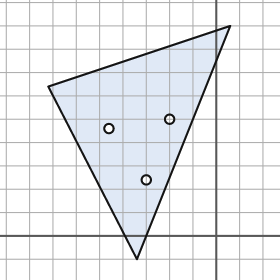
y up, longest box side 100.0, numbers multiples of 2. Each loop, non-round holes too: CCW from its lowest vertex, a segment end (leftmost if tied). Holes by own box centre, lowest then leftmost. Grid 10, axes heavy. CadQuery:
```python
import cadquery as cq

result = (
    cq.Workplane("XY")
    .moveTo(-34.0, -10.0)
    .lineTo(6.0, 90.0)
    .lineTo(-72.0, 64.0)
    .close()
    .moveTo(-30.0, 24.0)
    .circle(2.0)
    .moveTo(-46.0, 46.0)
    .circle(2.0)
    .moveTo(-20.0, 50.0)
    .circle(2.0)
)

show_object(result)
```